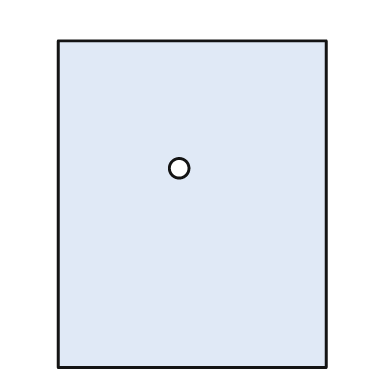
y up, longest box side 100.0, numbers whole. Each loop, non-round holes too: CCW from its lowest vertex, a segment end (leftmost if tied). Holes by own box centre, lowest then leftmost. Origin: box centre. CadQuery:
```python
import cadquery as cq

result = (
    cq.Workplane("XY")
    .moveTo(-41.0, -50.0)
    .lineTo(41.0, -50.0)
    .lineTo(41.0, 50.0)
    .lineTo(-41.0, 50.0)
    .close()
    .moveTo(-4.0, 11.0)
    .circle(3.0)
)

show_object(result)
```